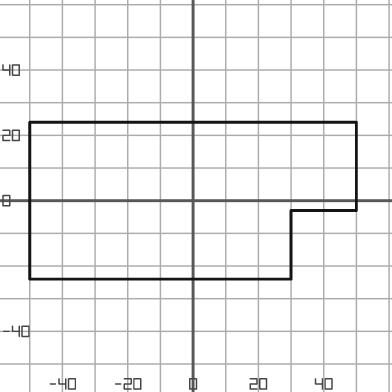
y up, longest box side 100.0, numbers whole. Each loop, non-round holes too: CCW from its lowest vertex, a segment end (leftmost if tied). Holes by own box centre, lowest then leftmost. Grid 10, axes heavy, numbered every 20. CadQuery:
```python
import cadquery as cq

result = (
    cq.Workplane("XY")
    .moveTo(-50.0, -24.0)
    .lineTo(30.0, -24.0)
    .lineTo(30.0, -3.0)
    .lineTo(50.0, -3.0)
    .lineTo(50.0, 24.0)
    .lineTo(-50.0, 24.0)
    .close()
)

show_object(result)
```